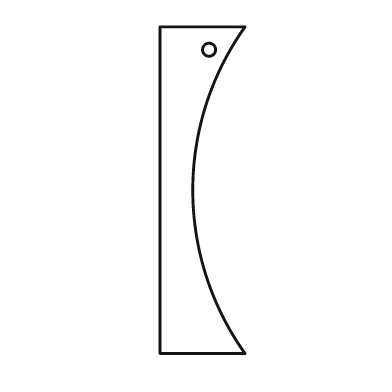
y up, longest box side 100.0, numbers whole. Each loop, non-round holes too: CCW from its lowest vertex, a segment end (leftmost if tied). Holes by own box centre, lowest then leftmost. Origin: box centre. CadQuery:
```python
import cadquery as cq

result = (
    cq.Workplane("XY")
    .moveTo(-13.0, -50.0)
    .lineTo(13.0, -50.0)
    .threePointArc((-3.0, 0.0), (13.0, 50.0))
    .lineTo(-13.0, 50.0)
    .close()
    .moveTo(2.0, 43.0)
    .circle(2.0)
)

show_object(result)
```